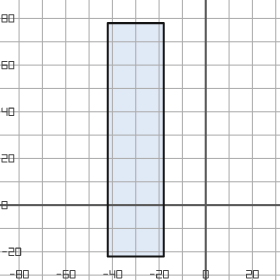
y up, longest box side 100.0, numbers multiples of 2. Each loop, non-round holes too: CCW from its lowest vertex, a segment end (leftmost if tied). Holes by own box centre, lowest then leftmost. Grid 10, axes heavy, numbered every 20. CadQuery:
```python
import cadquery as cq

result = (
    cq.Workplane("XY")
    .moveTo(-42.0, -22.0)
    .lineTo(-18.0, -22.0)
    .lineTo(-18.0, 78.0)
    .lineTo(-42.0, 78.0)
    .close()
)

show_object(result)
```